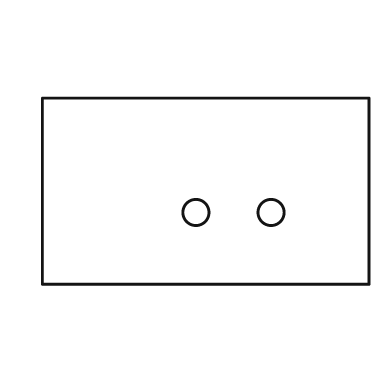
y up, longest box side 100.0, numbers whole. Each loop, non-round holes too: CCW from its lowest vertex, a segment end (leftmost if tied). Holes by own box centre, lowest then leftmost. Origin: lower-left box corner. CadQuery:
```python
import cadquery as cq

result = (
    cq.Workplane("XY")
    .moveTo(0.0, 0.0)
    .lineTo(100.0, 0.0)
    .lineTo(100.0, 57.0)
    .lineTo(0.0, 57.0)
    .close()
    .moveTo(47.0, 22.0)
    .circle(4.0)
    .moveTo(70.0, 22.0)
    .circle(4.0)
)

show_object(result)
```